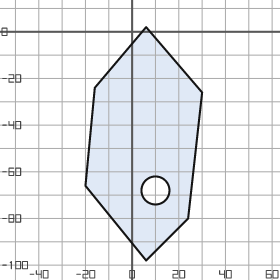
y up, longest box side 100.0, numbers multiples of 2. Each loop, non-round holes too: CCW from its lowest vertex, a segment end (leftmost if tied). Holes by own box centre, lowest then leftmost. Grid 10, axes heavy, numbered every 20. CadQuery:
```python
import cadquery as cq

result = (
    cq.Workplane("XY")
    .moveTo(6.0, -98.0)
    .lineTo(24.0, -80.0)
    .lineTo(30.0, -26.0)
    .lineTo(6.0, 2.0)
    .lineTo(-16.0, -24.0)
    .lineTo(-20.0, -66.0)
    .close()
    .moveTo(10.0, -68.0)
    .circle(6.0)
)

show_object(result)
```